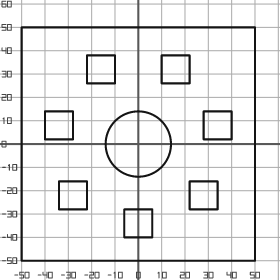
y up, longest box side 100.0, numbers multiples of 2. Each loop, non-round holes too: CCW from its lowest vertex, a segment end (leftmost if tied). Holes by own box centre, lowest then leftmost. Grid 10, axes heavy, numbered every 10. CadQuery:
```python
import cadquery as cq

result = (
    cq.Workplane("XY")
    .moveTo(-50.0, -50.0)
    .lineTo(50.0, -50.0)
    .lineTo(50.0, 50.0)
    .lineTo(-50.0, 50.0)
    .close()
    .moveTo(-6.0, -40.0)
    .lineTo(6.0, -40.0)
    .lineTo(6.0, -28.0)
    .lineTo(-6.0, -28.0)
    .close()
    .moveTo(-34.0, -28.0)
    .lineTo(-22.0, -28.0)
    .lineTo(-22.0, -16.0)
    .lineTo(-34.0, -16.0)
    .close()
    .moveTo(22.0, -28.0)
    .lineTo(34.0, -28.0)
    .lineTo(34.0, -16.0)
    .lineTo(22.0, -16.0)
    .close()
    .moveTo(0.0, 0.0)
    .circle(14.0)
    .moveTo(-40.0, 2.0)
    .lineTo(-28.0, 2.0)
    .lineTo(-28.0, 14.0)
    .lineTo(-40.0, 14.0)
    .close()
    .moveTo(28.0, 2.0)
    .lineTo(40.0, 2.0)
    .lineTo(40.0, 14.0)
    .lineTo(28.0, 14.0)
    .close()
    .moveTo(-22.0, 26.0)
    .lineTo(-10.0, 26.0)
    .lineTo(-10.0, 38.0)
    .lineTo(-22.0, 38.0)
    .close()
    .moveTo(10.0, 26.0)
    .lineTo(22.0, 26.0)
    .lineTo(22.0, 38.0)
    .lineTo(10.0, 38.0)
    .close()
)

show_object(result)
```